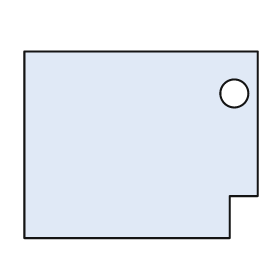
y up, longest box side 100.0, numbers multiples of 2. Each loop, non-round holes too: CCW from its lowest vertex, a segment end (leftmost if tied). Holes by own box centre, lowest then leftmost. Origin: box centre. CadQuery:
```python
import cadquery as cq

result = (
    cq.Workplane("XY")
    .moveTo(-50.0, -40.0)
    .lineTo(38.0, -40.0)
    .lineTo(38.0, -22.0)
    .lineTo(50.0, -22.0)
    .lineTo(50.0, 40.0)
    .lineTo(-50.0, 40.0)
    .close()
    .moveTo(40.0, 22.0)
    .circle(6.0)
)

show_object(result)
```